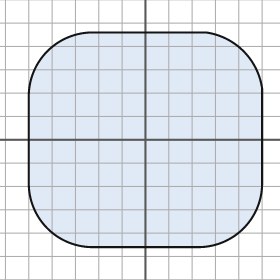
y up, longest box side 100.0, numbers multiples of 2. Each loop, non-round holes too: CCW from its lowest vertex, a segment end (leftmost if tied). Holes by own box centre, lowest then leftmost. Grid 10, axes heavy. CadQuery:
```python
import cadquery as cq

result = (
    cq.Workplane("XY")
    .moveTo(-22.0, -46.0)
    .lineTo(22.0, -46.0)
    .threePointArc((42.0, -38.0), (50.0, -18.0))
    .lineTo(50.0, 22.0)
    .threePointArc((42.0, 38.0), (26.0, 46.0))
    .lineTo(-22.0, 46.0)
    .threePointArc((-42.0, 38.0), (-50.0, 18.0))
    .lineTo(-50.0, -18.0)
    .threePointArc((-42.0, -38.0), (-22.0, -46.0))
    .close()
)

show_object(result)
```